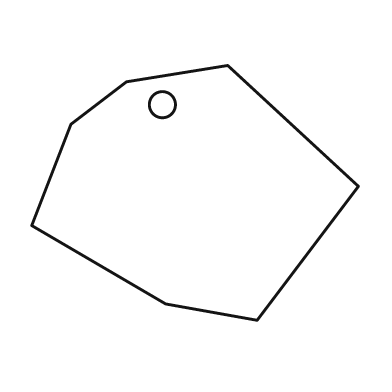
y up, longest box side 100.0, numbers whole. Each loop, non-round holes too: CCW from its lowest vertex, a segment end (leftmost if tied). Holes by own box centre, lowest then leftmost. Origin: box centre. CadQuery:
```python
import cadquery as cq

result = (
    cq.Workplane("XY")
    .moveTo(19.0, -39.0)
    .lineTo(50.0, 2.0)
    .lineTo(10.0, 39.0)
    .lineTo(-21.0, 34.0)
    .lineTo(-38.0, 21.0)
    .lineTo(-50.0, -10.0)
    .lineTo(-9.0, -34.0)
    .close()
    .moveTo(-10.0, 27.0)
    .circle(4.0)
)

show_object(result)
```